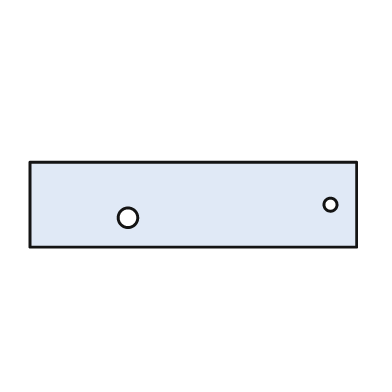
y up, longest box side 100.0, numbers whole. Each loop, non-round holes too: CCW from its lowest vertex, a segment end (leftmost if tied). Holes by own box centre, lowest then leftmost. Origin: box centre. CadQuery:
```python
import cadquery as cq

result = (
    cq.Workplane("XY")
    .moveTo(-50.0, -13.0)
    .lineTo(50.0, -13.0)
    .lineTo(50.0, 13.0)
    .lineTo(-50.0, 13.0)
    .close()
    .moveTo(-20.0, -4.0)
    .circle(3.0)
    .moveTo(42.0, 0.0)
    .circle(2.0)
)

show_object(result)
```